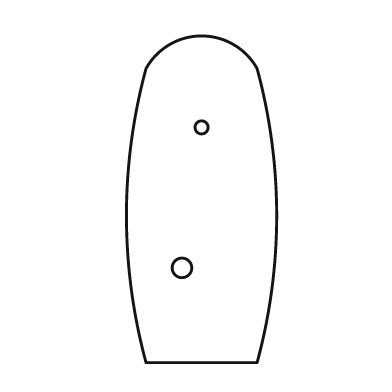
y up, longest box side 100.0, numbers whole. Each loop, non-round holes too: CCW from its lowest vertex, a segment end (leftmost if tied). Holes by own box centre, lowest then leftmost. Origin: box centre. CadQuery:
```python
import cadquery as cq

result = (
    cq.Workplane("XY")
    .moveTo(-17.0, -50.0)
    .lineTo(17.0, -50.0)
    .threePointArc((23.0, -5.0), (17.0, 40.0))
    .threePointArc((0.0, 50.0), (-17.0, 40.0))
    .threePointArc((-23.0, -5.0), (-17.0, -50.0))
    .close()
    .moveTo(-6.0, -21.0)
    .circle(3.0)
    .moveTo(0.0, 22.0)
    .circle(2.0)
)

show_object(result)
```